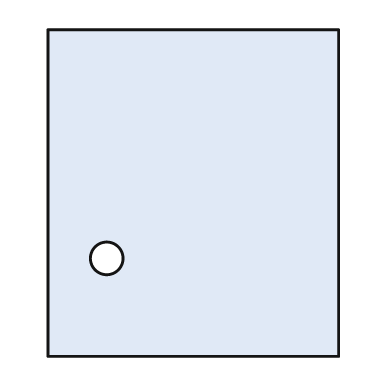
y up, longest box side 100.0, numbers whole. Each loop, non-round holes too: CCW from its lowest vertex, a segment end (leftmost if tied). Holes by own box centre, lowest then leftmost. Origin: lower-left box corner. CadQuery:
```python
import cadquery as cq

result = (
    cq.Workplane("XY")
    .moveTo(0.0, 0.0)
    .lineTo(89.0, 0.0)
    .lineTo(89.0, 100.0)
    .lineTo(0.0, 100.0)
    .close()
    .moveTo(18.0, 30.0)
    .circle(5.0)
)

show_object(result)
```